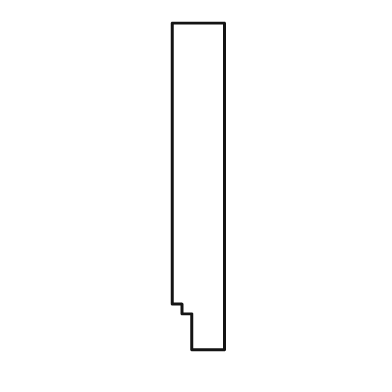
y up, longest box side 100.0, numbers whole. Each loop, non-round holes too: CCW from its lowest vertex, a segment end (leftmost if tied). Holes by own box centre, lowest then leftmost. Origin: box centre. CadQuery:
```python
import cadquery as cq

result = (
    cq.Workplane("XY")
    .moveTo(-2.0, -50.0)
    .lineTo(8.0, -50.0)
    .lineTo(8.0, 50.0)
    .lineTo(-8.0, 50.0)
    .lineTo(-8.0, -36.0)
    .lineTo(-5.0, -36.0)
    .lineTo(-5.0, -39.0)
    .lineTo(-2.0, -39.0)
    .close()
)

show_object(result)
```